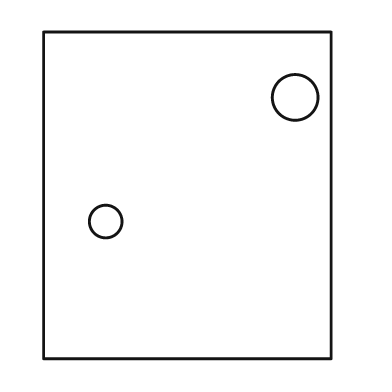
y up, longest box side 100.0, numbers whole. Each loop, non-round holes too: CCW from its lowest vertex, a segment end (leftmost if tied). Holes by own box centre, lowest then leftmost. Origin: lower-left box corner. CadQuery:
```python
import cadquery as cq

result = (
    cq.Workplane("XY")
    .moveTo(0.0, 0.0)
    .lineTo(88.0, 0.0)
    .lineTo(88.0, 100.0)
    .lineTo(0.0, 100.0)
    .close()
    .moveTo(19.0, 42.0)
    .circle(5.0)
    .moveTo(77.0, 80.0)
    .circle(7.0)
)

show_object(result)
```